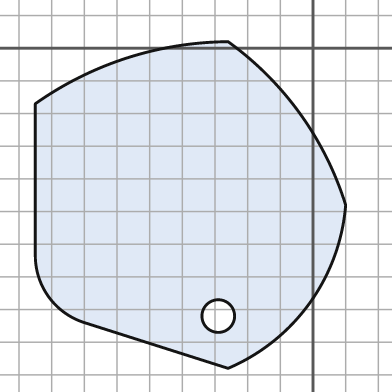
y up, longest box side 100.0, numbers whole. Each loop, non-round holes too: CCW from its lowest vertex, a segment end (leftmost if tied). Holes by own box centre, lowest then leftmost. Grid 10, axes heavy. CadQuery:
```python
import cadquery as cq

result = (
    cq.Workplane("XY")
    .moveTo(-26.0, -98.0)
    .threePointArc((-1.0, -78.0), (10.0, -48.0))
    .threePointArc((-4.0, -20.0), (-26.0, 2.0))
    .threePointArc((-57.0, -3.0), (-85.0, -17.0))
    .lineTo(-85.0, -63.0)
    .threePointArc((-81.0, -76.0), (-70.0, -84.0))
    .close()
    .moveTo(-29.0, -82.0)
    .circle(5.0)
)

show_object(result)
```